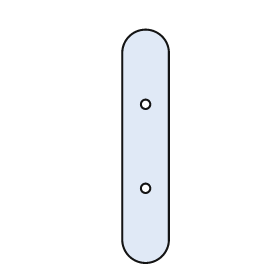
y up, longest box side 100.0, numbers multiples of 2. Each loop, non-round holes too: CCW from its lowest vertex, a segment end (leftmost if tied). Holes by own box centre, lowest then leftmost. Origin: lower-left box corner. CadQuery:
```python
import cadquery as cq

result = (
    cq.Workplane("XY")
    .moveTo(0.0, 10.0)
    .threePointArc((10.0, 0.0), (20.0, 10.0))
    .lineTo(20.0, 90.0)
    .threePointArc((10.0, 100.0), (0.0, 90.0))
    .close()
    .moveTo(10.0, 32.0)
    .circle(2.0)
    .moveTo(10.0, 68.0)
    .circle(2.0)
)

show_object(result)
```